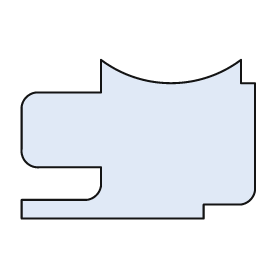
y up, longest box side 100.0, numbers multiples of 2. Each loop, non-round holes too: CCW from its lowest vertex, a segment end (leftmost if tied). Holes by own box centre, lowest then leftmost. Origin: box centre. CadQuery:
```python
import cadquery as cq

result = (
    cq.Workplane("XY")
    .moveTo(-50.0, -34.0)
    .lineTo(28.0, -34.0)
    .lineTo(28.0, -28.0)
    .lineTo(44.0, -28.0)
    .threePointArc((48.0, -26.0), (50.0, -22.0))
    .lineTo(50.0, 24.0)
    .lineTo(44.0, 24.0)
    .lineTo(44.0, 34.0)
    .threePointArc((14.0, 24.0), (-16.0, 34.0))
    .lineTo(-16.0, 20.0)
    .lineTo(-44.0, 20.0)
    .threePointArc((-48.0, 18.0), (-50.0, 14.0))
    .lineTo(-50.0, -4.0)
    .threePointArc((-48.0, -10.0), (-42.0, -12.0))
    .lineTo(-16.0, -12.0)
    .lineTo(-16.0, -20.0)
    .threePointArc((-18.0, -24.0), (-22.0, -26.0))
    .lineTo(-50.0, -26.0)
    .close()
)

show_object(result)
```